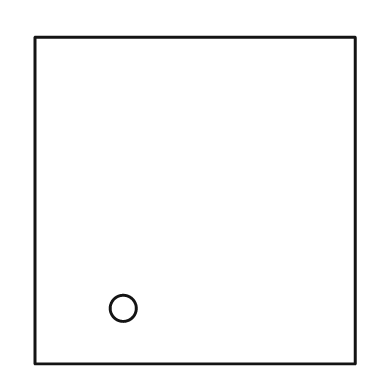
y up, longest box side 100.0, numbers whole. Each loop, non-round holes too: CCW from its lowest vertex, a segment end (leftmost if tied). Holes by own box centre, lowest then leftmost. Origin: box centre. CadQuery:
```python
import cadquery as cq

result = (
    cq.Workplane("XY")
    .moveTo(-49.0, -50.0)
    .lineTo(49.0, -50.0)
    .lineTo(49.0, 50.0)
    .lineTo(-49.0, 50.0)
    .close()
    .moveTo(-22.0, -33.0)
    .circle(4.0)
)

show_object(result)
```